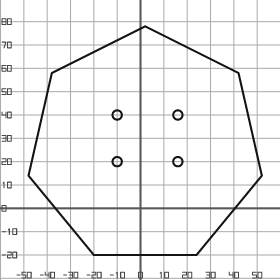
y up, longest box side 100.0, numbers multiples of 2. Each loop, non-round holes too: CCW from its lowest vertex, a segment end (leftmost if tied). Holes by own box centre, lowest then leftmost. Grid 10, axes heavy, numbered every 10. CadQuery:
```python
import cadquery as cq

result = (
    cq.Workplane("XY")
    .moveTo(-20.0, -20.0)
    .lineTo(24.0, -20.0)
    .lineTo(52.0, 14.0)
    .lineTo(42.0, 58.0)
    .lineTo(2.0, 78.0)
    .lineTo(-38.0, 58.0)
    .lineTo(-48.0, 14.0)
    .close()
    .moveTo(-10.0, 20.0)
    .circle(2.0)
    .moveTo(16.0, 20.0)
    .circle(2.0)
    .moveTo(-10.0, 40.0)
    .circle(2.0)
    .moveTo(16.0, 40.0)
    .circle(2.0)
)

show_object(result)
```